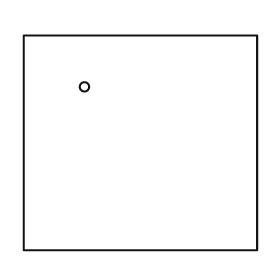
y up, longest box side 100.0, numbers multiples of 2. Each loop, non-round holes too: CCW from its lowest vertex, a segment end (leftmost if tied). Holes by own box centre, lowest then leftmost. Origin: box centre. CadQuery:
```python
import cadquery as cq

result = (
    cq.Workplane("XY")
    .moveTo(-50.0, -46.0)
    .lineTo(50.0, -46.0)
    .lineTo(50.0, 46.0)
    .lineTo(-50.0, 46.0)
    .close()
    .moveTo(-24.0, 24.0)
    .circle(2.0)
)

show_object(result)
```